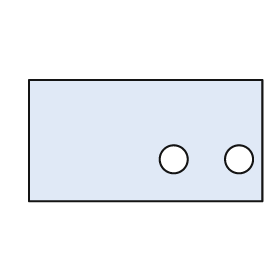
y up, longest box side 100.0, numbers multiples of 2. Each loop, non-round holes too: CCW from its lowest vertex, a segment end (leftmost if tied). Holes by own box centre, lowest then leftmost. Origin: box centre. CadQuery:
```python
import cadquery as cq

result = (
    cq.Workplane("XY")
    .moveTo(-50.0, -26.0)
    .lineTo(50.0, -26.0)
    .lineTo(50.0, 26.0)
    .lineTo(-50.0, 26.0)
    .close()
    .moveTo(12.0, -8.0)
    .circle(6.0)
    .moveTo(40.0, -8.0)
    .circle(6.0)
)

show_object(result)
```